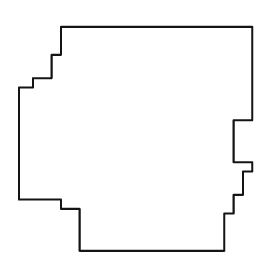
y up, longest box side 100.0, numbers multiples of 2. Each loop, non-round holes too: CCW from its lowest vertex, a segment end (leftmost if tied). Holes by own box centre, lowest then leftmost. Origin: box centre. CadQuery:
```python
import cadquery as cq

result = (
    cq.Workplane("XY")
    .moveTo(-24.0, -48.0)
    .lineTo(38.0, -48.0)
    .lineTo(38.0, -32.0)
    .lineTo(42.0, -32.0)
    .lineTo(42.0, -24.0)
    .lineTo(46.0, -24.0)
    .lineTo(46.0, -14.0)
    .lineTo(50.0, -14.0)
    .lineTo(50.0, -10.0)
    .lineTo(42.0, -10.0)
    .lineTo(42.0, 8.0)
    .lineTo(50.0, 8.0)
    .lineTo(50.0, 48.0)
    .lineTo(-32.0, 48.0)
    .lineTo(-32.0, 36.0)
    .lineTo(-36.0, 36.0)
    .lineTo(-36.0, 26.0)
    .lineTo(-44.0, 26.0)
    .lineTo(-44.0, 22.0)
    .lineTo(-50.0, 22.0)
    .lineTo(-50.0, -26.0)
    .lineTo(-32.0, -26.0)
    .lineTo(-32.0, -30.0)
    .lineTo(-24.0, -30.0)
    .close()
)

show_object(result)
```